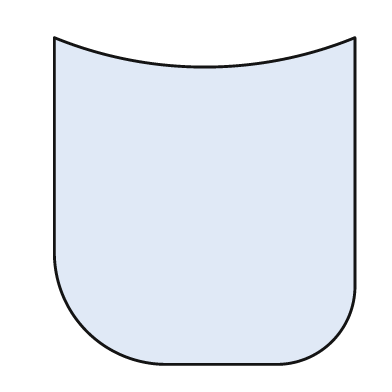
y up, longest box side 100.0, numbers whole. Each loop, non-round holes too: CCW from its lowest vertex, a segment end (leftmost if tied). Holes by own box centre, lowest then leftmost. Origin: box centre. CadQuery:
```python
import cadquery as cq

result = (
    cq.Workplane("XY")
    .moveTo(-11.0, -50.0)
    .lineTo(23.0, -50.0)
    .threePointArc((39.0, -43.0), (46.0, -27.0))
    .lineTo(46.0, 50.0)
    .threePointArc((0.0, 41.0), (-46.0, 50.0))
    .lineTo(-46.0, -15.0)
    .threePointArc((-36.0, -40.0), (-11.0, -50.0))
    .close()
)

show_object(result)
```